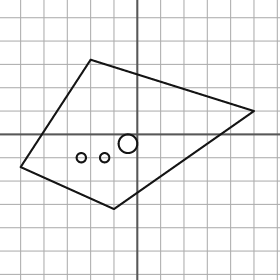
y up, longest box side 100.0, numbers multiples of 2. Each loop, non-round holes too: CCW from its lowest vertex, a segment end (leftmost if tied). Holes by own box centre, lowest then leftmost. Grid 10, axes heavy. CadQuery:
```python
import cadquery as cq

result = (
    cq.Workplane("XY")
    .moveTo(-10.0, -32.0)
    .lineTo(50.0, 10.0)
    .lineTo(-20.0, 32.0)
    .lineTo(-50.0, -14.0)
    .close()
    .moveTo(-24.0, -10.0)
    .circle(2.0)
    .moveTo(-14.0, -10.0)
    .circle(2.0)
    .moveTo(-4.0, -4.0)
    .circle(4.0)
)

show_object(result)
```